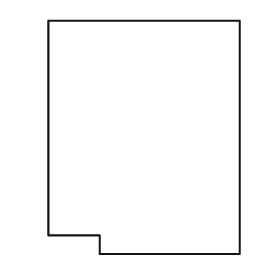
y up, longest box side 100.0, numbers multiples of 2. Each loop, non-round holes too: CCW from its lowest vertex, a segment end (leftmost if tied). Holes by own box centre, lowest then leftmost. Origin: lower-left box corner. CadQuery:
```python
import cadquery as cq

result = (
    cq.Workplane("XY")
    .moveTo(22.0, 0.0)
    .lineTo(82.0, 0.0)
    .lineTo(82.0, 100.0)
    .lineTo(0.0, 100.0)
    .lineTo(0.0, 8.0)
    .lineTo(22.0, 8.0)
    .close()
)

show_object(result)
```